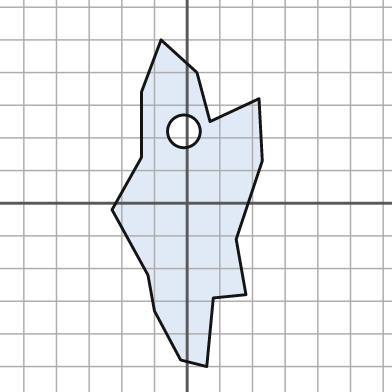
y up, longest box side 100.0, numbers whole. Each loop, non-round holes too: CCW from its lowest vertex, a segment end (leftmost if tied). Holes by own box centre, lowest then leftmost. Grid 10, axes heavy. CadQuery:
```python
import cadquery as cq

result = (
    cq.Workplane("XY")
    .moveTo(6.0, -50.0)
    .lineTo(8.0, -29.0)
    .lineTo(18.0, -28.0)
    .lineTo(15.0, -11.0)
    .lineTo(23.0, 13.0)
    .lineTo(22.0, 32.0)
    .lineTo(7.0, 25.0)
    .lineTo(3.0, 40.0)
    .lineTo(-8.0, 50.0)
    .lineTo(-14.0, 34.0)
    .lineTo(-14.0, 14.0)
    .lineTo(-23.0, -2.0)
    .lineTo(-12.0, -22.0)
    .lineTo(-10.0, -33.0)
    .lineTo(-2.0, -48.0)
    .close()
    .moveTo(-1.0, 22.0)
    .circle(5.0)
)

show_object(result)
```